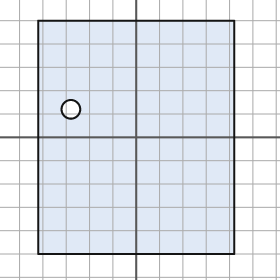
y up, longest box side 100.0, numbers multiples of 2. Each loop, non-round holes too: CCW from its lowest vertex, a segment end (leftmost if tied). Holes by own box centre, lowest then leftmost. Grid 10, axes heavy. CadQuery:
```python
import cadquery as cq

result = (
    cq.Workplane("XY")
    .moveTo(-42.0, -50.0)
    .lineTo(42.0, -50.0)
    .lineTo(42.0, 50.0)
    .lineTo(-42.0, 50.0)
    .close()
    .moveTo(-28.0, 12.0)
    .circle(4.0)
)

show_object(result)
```